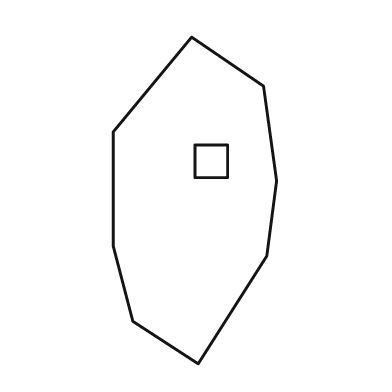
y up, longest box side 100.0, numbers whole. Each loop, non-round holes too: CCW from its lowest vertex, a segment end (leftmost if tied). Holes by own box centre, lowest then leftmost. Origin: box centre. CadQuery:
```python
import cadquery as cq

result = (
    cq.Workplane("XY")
    .moveTo(1.0, -50.0)
    .lineTo(22.0, -17.0)
    .lineTo(25.0, 6.0)
    .lineTo(21.0, 35.0)
    .lineTo(-1.0, 50.0)
    .lineTo(-25.0, 21.0)
    .lineTo(-25.0, -14.0)
    .lineTo(-19.0, -37.0)
    .close()
    .moveTo(0.0, 7.0)
    .lineTo(10.0, 7.0)
    .lineTo(10.0, 17.0)
    .lineTo(0.0, 17.0)
    .close()
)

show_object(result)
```